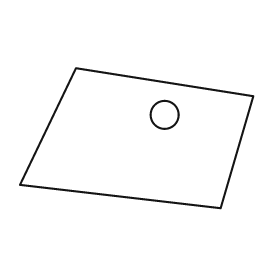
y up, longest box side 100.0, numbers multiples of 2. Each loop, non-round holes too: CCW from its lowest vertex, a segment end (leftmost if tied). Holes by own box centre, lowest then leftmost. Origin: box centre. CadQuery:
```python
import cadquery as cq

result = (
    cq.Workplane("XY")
    .moveTo(36.0, -30.0)
    .lineTo(50.0, 18.0)
    .lineTo(-26.0, 30.0)
    .lineTo(-50.0, -20.0)
    .close()
    .moveTo(12.0, 10.0)
    .circle(6.0)
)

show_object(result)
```